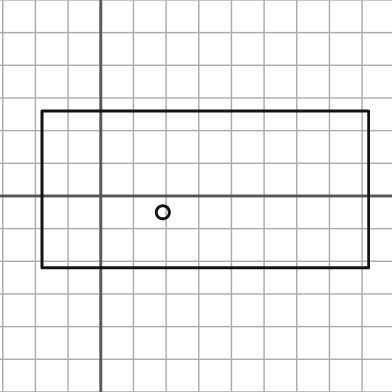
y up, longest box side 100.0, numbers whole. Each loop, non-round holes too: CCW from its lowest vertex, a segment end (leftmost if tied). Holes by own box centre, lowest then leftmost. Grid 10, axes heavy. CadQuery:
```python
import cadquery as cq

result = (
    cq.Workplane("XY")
    .moveTo(-18.0, -22.0)
    .lineTo(82.0, -22.0)
    .lineTo(82.0, 26.0)
    .lineTo(-18.0, 26.0)
    .close()
    .moveTo(19.0, -5.0)
    .circle(2.0)
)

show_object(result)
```